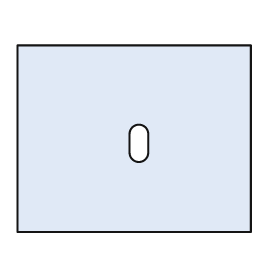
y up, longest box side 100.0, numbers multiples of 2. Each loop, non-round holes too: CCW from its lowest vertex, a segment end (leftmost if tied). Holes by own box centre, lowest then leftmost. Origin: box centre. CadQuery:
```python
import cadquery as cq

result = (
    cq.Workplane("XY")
    .moveTo(-50.0, -40.0)
    .lineTo(50.0, -40.0)
    .lineTo(50.0, 40.0)
    .lineTo(-50.0, 40.0)
    .close()
    .moveTo(-2.0, -6.0)
    .threePointArc((2.0, -10.0), (6.0, -6.0))
    .lineTo(6.0, 2.0)
    .threePointArc((2.0, 6.0), (-2.0, 2.0))
    .close()
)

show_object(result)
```